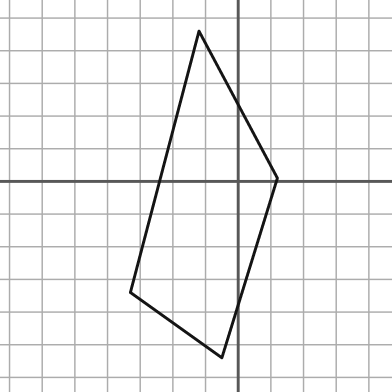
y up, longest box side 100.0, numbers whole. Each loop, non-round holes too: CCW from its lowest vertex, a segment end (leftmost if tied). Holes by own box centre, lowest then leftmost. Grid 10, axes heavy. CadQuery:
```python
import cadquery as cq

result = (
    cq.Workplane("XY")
    .moveTo(-5.0, -54.0)
    .lineTo(12.0, 1.0)
    .lineTo(-12.0, 46.0)
    .lineTo(-33.0, -34.0)
    .close()
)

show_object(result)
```